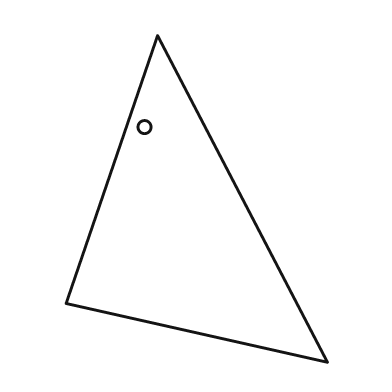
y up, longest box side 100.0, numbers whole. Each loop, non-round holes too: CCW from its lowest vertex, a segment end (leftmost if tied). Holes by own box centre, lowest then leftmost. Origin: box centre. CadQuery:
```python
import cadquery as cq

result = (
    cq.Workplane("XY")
    .moveTo(40.0, -50.0)
    .lineTo(-12.0, 50.0)
    .lineTo(-40.0, -32.0)
    .close()
    .moveTo(-16.0, 22.0)
    .circle(2.0)
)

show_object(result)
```